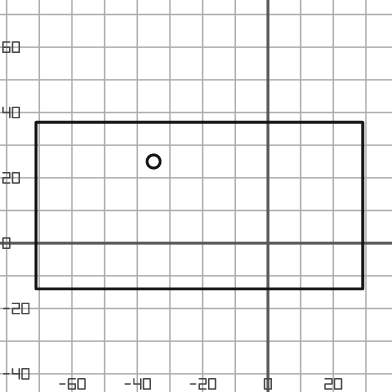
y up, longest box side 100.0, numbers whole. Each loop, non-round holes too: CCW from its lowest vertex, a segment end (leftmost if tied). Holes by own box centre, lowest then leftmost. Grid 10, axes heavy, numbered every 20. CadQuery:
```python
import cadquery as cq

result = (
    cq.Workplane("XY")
    .moveTo(-71.0, -14.0)
    .lineTo(29.0, -14.0)
    .lineTo(29.0, 37.0)
    .lineTo(-71.0, 37.0)
    .close()
    .moveTo(-35.0, 25.0)
    .circle(2.0)
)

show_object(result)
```